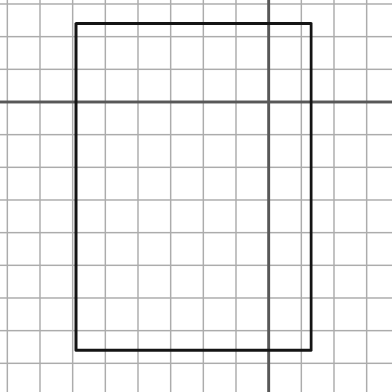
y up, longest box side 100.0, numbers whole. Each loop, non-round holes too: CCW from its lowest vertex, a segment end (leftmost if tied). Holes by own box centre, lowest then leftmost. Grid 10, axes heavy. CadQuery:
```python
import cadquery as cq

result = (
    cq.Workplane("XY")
    .moveTo(-59.0, -76.0)
    .lineTo(13.0, -76.0)
    .lineTo(13.0, 24.0)
    .lineTo(-59.0, 24.0)
    .close()
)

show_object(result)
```